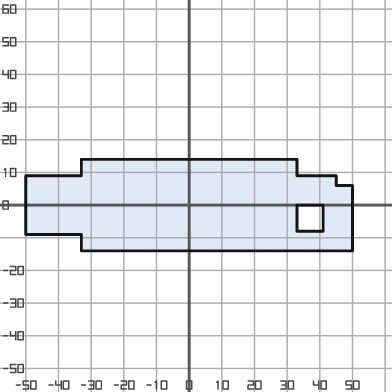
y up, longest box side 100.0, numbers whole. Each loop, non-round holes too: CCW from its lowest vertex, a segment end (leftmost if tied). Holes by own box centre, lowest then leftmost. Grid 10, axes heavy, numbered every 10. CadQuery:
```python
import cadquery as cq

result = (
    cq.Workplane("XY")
    .moveTo(-33.0, -14.0)
    .lineTo(50.0, -14.0)
    .lineTo(50.0, 6.0)
    .lineTo(45.0, 6.0)
    .lineTo(45.0, 9.0)
    .lineTo(33.0, 9.0)
    .lineTo(33.0, 14.0)
    .lineTo(-33.0, 14.0)
    .lineTo(-33.0, 9.0)
    .lineTo(-50.0, 9.0)
    .lineTo(-50.0, -9.0)
    .lineTo(-33.0, -9.0)
    .close()
    .moveTo(33.0, -8.0)
    .lineTo(41.0, -8.0)
    .lineTo(41.0, 0.0)
    .lineTo(33.0, 0.0)
    .close()
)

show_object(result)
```